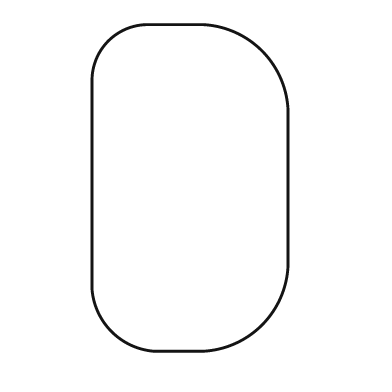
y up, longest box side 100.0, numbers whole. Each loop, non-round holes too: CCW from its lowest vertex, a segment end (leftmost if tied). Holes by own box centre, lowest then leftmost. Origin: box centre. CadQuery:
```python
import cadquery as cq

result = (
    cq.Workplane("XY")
    .moveTo(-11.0, -50.0)
    .lineTo(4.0, -50.0)
    .threePointArc((22.0, -42.0), (30.0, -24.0))
    .lineTo(30.0, 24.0)
    .threePointArc((22.0, 42.0), (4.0, 50.0))
    .lineTo(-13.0, 50.0)
    .threePointArc((-25.0, 45.0), (-30.0, 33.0))
    .lineTo(-30.0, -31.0)
    .threePointArc((-24.0, -44.0), (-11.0, -50.0))
    .close()
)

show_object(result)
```